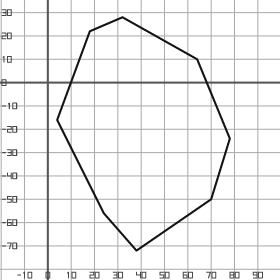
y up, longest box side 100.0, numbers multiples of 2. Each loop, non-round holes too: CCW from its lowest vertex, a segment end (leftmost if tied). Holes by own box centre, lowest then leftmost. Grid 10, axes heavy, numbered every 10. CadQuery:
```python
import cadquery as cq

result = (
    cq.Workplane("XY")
    .moveTo(38.0, -72.0)
    .lineTo(70.0, -50.0)
    .lineTo(78.0, -24.0)
    .lineTo(64.0, 10.0)
    .lineTo(32.0, 28.0)
    .lineTo(18.0, 22.0)
    .lineTo(4.0, -16.0)
    .lineTo(24.0, -56.0)
    .close()
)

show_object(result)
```